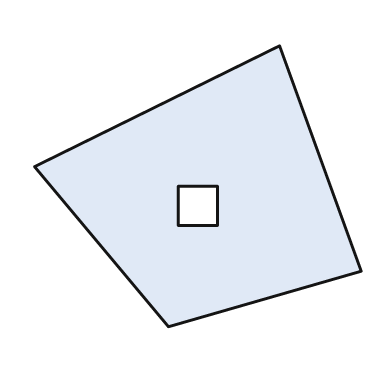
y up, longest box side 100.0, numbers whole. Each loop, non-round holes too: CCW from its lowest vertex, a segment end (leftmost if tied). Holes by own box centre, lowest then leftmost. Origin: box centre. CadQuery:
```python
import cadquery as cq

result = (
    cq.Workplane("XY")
    .moveTo(-9.0, -43.0)
    .lineTo(50.0, -26.0)
    .lineTo(25.0, 43.0)
    .lineTo(-50.0, 6.0)
    .close()
    .moveTo(-6.0, -12.0)
    .lineTo(6.0, -12.0)
    .lineTo(6.0, 0.0)
    .lineTo(-6.0, 0.0)
    .close()
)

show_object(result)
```